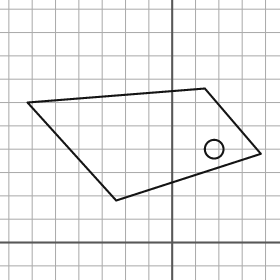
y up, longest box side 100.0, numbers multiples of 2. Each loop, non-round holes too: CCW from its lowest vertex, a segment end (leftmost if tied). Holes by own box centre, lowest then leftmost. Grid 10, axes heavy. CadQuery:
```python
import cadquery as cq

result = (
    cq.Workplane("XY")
    .moveTo(-24.0, 18.0)
    .lineTo(38.0, 38.0)
    .lineTo(14.0, 66.0)
    .lineTo(-62.0, 60.0)
    .close()
    .moveTo(18.0, 40.0)
    .circle(4.0)
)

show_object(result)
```